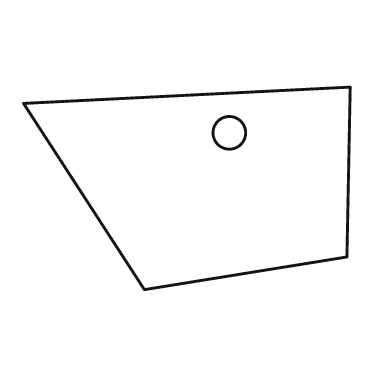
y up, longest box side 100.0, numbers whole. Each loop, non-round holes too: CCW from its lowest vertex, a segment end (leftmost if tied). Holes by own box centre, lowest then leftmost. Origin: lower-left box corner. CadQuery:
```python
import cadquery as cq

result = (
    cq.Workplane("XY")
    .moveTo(37.0, 0.0)
    .lineTo(99.0, 10.0)
    .lineTo(100.0, 62.0)
    .lineTo(0.0, 57.0)
    .close()
    .moveTo(63.0, 48.0)
    .circle(5.0)
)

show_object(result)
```